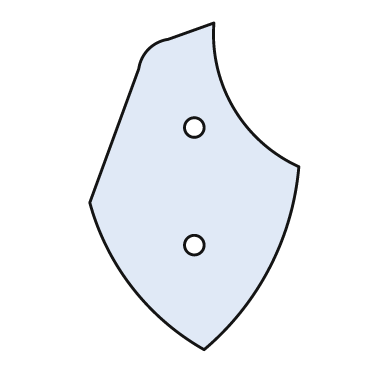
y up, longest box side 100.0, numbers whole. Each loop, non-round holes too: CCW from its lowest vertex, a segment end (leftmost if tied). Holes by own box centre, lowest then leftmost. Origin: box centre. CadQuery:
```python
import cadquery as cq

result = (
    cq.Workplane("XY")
    .moveTo(3.0, -50.0)
    .threePointArc((23.0, -25.0), (32.0, 6.0))
    .threePointArc((12.0, 24.0), (6.0, 50.0))
    .lineTo(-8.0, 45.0)
    .threePointArc((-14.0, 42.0), (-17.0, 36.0))
    .lineTo(-32.0, -5.0)
    .threePointArc((-19.0, -31.0), (3.0, -50.0))
    .close()
    .moveTo(0.0, -18.0)
    .circle(3.0)
    .moveTo(0.0, 18.0)
    .circle(3.0)
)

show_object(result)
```